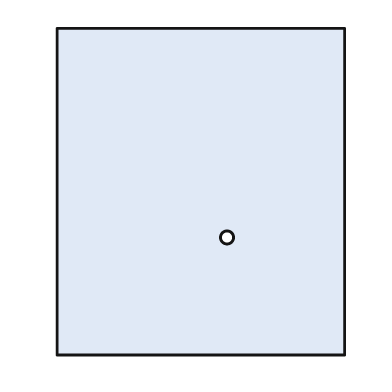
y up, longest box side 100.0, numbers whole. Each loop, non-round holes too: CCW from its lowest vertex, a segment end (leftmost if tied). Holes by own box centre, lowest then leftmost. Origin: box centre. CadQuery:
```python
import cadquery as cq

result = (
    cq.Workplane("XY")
    .moveTo(-44.0, -50.0)
    .lineTo(44.0, -50.0)
    .lineTo(44.0, 50.0)
    .lineTo(-44.0, 50.0)
    .close()
    .moveTo(8.0, -14.0)
    .circle(2.0)
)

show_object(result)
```